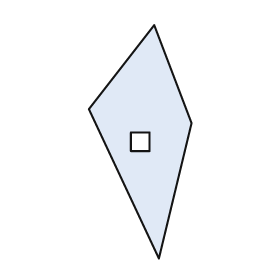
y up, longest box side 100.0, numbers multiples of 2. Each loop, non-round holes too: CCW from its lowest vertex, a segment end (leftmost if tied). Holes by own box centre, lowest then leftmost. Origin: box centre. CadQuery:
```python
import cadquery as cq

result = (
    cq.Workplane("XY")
    .moveTo(8.0, -50.0)
    .lineTo(22.0, 8.0)
    .lineTo(6.0, 50.0)
    .lineTo(-22.0, 14.0)
    .close()
    .moveTo(-4.0, -4.0)
    .lineTo(4.0, -4.0)
    .lineTo(4.0, 4.0)
    .lineTo(-4.0, 4.0)
    .close()
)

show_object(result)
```